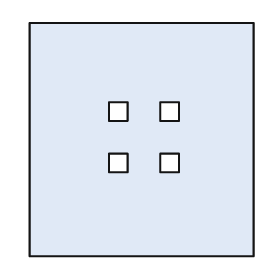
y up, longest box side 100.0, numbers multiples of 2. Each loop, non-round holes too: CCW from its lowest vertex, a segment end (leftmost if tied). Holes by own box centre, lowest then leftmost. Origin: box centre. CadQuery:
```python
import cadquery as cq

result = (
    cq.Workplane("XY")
    .moveTo(-48.0, -50.0)
    .lineTo(48.0, -50.0)
    .lineTo(48.0, 50.0)
    .lineTo(-48.0, 50.0)
    .close()
    .moveTo(-14.0, -14.0)
    .lineTo(-6.0, -14.0)
    .lineTo(-6.0, -6.0)
    .lineTo(-14.0, -6.0)
    .close()
    .moveTo(8.0, -14.0)
    .lineTo(16.0, -14.0)
    .lineTo(16.0, -6.0)
    .lineTo(8.0, -6.0)
    .close()
    .moveTo(-14.0, 8.0)
    .lineTo(-6.0, 8.0)
    .lineTo(-6.0, 16.0)
    .lineTo(-14.0, 16.0)
    .close()
    .moveTo(8.0, 8.0)
    .lineTo(16.0, 8.0)
    .lineTo(16.0, 16.0)
    .lineTo(8.0, 16.0)
    .close()
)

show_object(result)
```